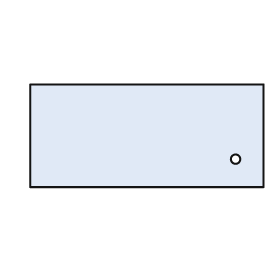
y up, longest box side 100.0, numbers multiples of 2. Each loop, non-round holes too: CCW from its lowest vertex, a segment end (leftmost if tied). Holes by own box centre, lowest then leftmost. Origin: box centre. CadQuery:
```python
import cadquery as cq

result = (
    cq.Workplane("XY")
    .moveTo(-50.0, -22.0)
    .lineTo(50.0, -22.0)
    .lineTo(50.0, 22.0)
    .lineTo(-50.0, 22.0)
    .close()
    .moveTo(38.0, -10.0)
    .circle(2.0)
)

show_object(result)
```